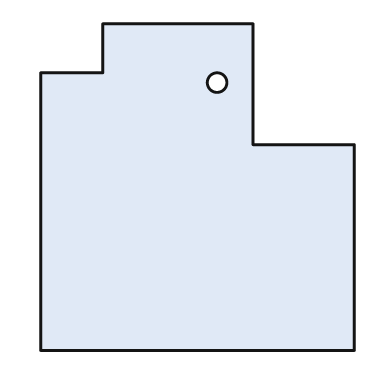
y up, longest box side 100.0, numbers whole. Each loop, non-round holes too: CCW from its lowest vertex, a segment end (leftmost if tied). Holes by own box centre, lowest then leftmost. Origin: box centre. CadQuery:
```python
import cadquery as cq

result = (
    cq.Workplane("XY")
    .moveTo(-48.0, -50.0)
    .lineTo(48.0, -50.0)
    .lineTo(48.0, 13.0)
    .lineTo(17.0, 13.0)
    .lineTo(17.0, 50.0)
    .lineTo(-29.0, 50.0)
    .lineTo(-29.0, 35.0)
    .lineTo(-48.0, 35.0)
    .close()
    .moveTo(6.0, 32.0)
    .circle(3.0)
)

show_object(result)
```